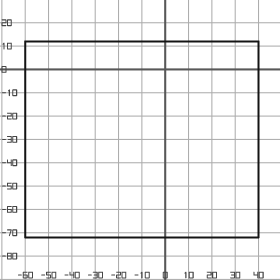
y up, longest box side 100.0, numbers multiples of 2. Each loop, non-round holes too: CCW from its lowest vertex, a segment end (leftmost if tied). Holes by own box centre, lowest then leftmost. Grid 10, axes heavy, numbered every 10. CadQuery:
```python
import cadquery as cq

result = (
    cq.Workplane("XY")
    .moveTo(-60.0, -72.0)
    .lineTo(40.0, -72.0)
    .lineTo(40.0, 12.0)
    .lineTo(-60.0, 12.0)
    .close()
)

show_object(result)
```